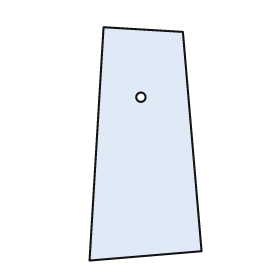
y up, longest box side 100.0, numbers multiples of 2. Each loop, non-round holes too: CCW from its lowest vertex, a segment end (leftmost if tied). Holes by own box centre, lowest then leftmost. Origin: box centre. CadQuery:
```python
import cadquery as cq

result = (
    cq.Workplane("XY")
    .moveTo(-24.0, -50.0)
    .lineTo(24.0, -46.0)
    .lineTo(16.0, 48.0)
    .lineTo(-18.0, 50.0)
    .close()
    .moveTo(-2.0, 20.0)
    .circle(2.0)
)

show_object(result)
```